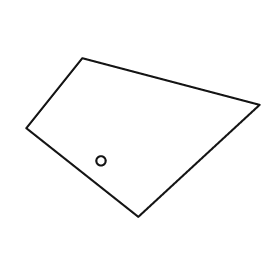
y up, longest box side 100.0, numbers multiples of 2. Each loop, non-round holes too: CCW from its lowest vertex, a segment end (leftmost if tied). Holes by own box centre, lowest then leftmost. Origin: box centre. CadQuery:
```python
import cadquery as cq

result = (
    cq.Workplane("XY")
    .moveTo(-2.0, -34.0)
    .lineTo(50.0, 14.0)
    .lineTo(-26.0, 34.0)
    .lineTo(-50.0, 4.0)
    .close()
    .moveTo(-18.0, -10.0)
    .circle(2.0)
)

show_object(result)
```